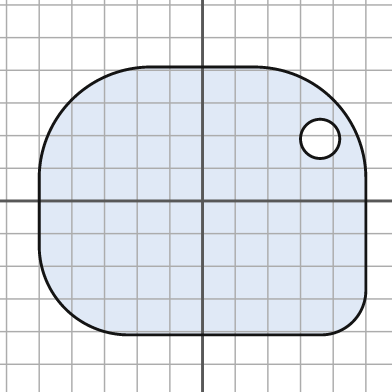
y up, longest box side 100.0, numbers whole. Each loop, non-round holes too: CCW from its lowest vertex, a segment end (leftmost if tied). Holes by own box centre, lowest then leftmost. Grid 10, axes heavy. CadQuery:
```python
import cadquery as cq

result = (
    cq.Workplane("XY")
    .moveTo(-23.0, -41.0)
    .lineTo(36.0, -41.0)
    .threePointArc((46.0, -37.0), (50.0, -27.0))
    .lineTo(50.0, 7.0)
    .threePointArc((40.0, 31.0), (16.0, 41.0))
    .lineTo(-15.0, 41.0)
    .threePointArc((-40.0, 31.0), (-50.0, 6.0))
    .lineTo(-50.0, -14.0)
    .threePointArc((-42.0, -33.0), (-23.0, -41.0))
    .close()
    .moveTo(36.0, 19.0)
    .circle(6.0)
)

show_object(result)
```